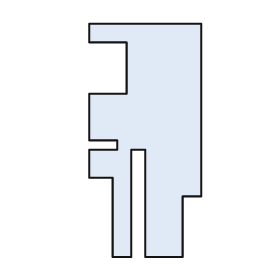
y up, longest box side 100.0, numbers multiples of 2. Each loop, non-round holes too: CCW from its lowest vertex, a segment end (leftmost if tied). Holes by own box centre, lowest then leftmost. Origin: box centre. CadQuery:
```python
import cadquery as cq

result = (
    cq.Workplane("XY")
    .moveTo(-14.0, -50.0)
    .lineTo(-6.0, -50.0)
    .lineTo(-6.0, -4.0)
    .lineTo(0.0, -4.0)
    .lineTo(0.0, -50.0)
    .lineTo(16.0, -50.0)
    .lineTo(16.0, -24.0)
    .lineTo(24.0, -24.0)
    .lineTo(24.0, 50.0)
    .lineTo(-24.0, 50.0)
    .lineTo(-24.0, 42.0)
    .lineTo(-8.0, 42.0)
    .lineTo(-8.0, 20.0)
    .lineTo(-24.0, 20.0)
    .lineTo(-24.0, 0.0)
    .lineTo(-12.0, 0.0)
    .lineTo(-12.0, -4.0)
    .lineTo(-24.0, -4.0)
    .lineTo(-24.0, -16.0)
    .lineTo(-14.0, -16.0)
    .close()
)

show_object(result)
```